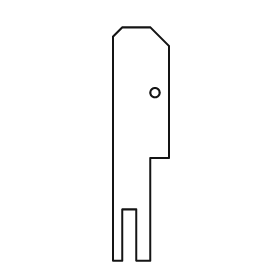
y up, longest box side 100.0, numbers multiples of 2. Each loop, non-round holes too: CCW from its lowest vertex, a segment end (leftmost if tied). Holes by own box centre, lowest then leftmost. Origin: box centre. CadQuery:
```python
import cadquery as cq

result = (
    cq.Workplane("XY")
    .moveTo(-12.0, -50.0)
    .lineTo(-8.0, -50.0)
    .lineTo(-8.0, -28.0)
    .lineTo(-2.0, -28.0)
    .lineTo(-2.0, -50.0)
    .lineTo(4.0, -50.0)
    .lineTo(4.0, -6.0)
    .lineTo(12.0, -6.0)
    .lineTo(12.0, 42.0)
    .lineTo(4.0, 50.0)
    .lineTo(-8.0, 50.0)
    .lineTo(-12.0, 46.0)
    .close()
    .moveTo(6.0, 22.0)
    .circle(2.0)
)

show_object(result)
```